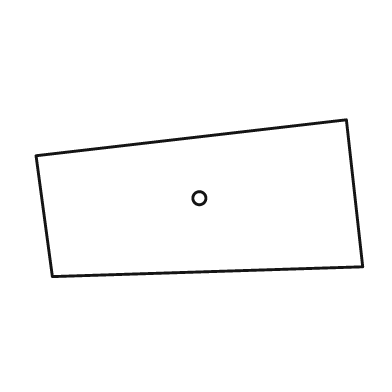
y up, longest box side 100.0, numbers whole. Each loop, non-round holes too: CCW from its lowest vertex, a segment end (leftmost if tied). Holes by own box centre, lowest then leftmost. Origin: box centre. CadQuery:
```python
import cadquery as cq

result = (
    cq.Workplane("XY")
    .moveTo(-45.0, -24.0)
    .lineTo(50.0, -21.0)
    .lineTo(45.0, 24.0)
    .lineTo(-50.0, 13.0)
    .close()
    .moveTo(0.0, 0.0)
    .circle(2.0)
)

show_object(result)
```